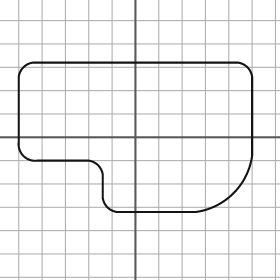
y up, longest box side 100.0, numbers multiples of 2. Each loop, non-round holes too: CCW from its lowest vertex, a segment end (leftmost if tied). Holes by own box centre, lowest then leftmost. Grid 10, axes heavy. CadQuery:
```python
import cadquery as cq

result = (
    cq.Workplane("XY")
    .moveTo(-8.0, -32.0)
    .lineTo(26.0, -32.0)
    .threePointArc((42.0, -24.0), (50.0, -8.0))
    .lineTo(50.0, 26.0)
    .threePointArc((48.0, 30.0), (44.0, 32.0))
    .lineTo(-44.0, 32.0)
    .threePointArc((-48.0, 30.0), (-50.0, 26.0))
    .lineTo(-50.0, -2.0)
    .threePointArc((-48.0, -8.0), (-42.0, -10.0))
    .lineTo(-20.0, -10.0)
    .threePointArc((-16.0, -12.0), (-14.0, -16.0))
    .lineTo(-14.0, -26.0)
    .threePointArc((-12.0, -30.0), (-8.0, -32.0))
    .close()
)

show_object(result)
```